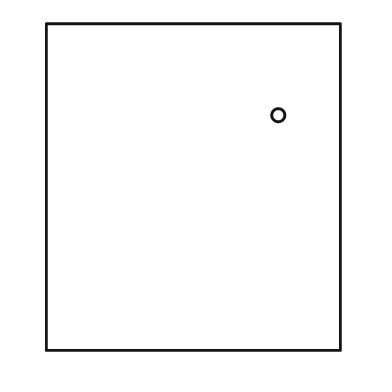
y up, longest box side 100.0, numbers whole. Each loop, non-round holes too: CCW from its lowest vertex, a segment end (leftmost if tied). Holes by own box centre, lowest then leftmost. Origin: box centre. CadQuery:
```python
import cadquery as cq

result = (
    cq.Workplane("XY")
    .moveTo(-45.0, -50.0)
    .lineTo(45.0, -50.0)
    .lineTo(45.0, 50.0)
    .lineTo(-45.0, 50.0)
    .close()
    .moveTo(26.0, 22.0)
    .circle(2.0)
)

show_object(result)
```